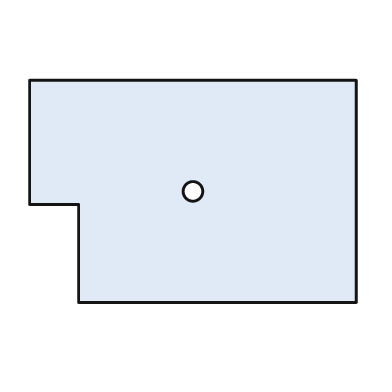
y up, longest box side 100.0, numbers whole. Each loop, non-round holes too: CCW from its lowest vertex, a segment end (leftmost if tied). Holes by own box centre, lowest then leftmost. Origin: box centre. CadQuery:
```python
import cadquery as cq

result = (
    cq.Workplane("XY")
    .moveTo(-35.0, -34.0)
    .lineTo(50.0, -34.0)
    .lineTo(50.0, 34.0)
    .lineTo(-50.0, 34.0)
    .lineTo(-50.0, -4.0)
    .lineTo(-35.0, -4.0)
    .close()
    .moveTo(0.0, 0.0)
    .circle(3.0)
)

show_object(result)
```